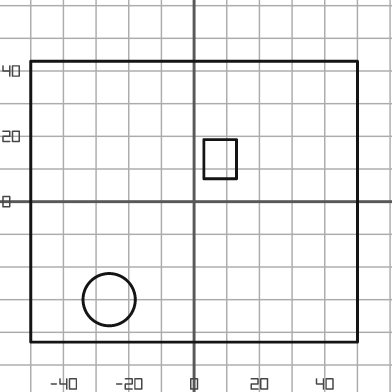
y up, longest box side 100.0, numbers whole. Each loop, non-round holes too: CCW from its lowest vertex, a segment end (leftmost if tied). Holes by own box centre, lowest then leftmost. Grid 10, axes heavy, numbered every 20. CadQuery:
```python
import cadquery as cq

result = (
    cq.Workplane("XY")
    .moveTo(-50.0, -43.0)
    .lineTo(50.0, -43.0)
    .lineTo(50.0, 43.0)
    .lineTo(-50.0, 43.0)
    .close()
    .moveTo(-26.0, -30.0)
    .circle(8.0)
    .moveTo(3.0, 7.0)
    .lineTo(13.0, 7.0)
    .lineTo(13.0, 19.0)
    .lineTo(3.0, 19.0)
    .close()
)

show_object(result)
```